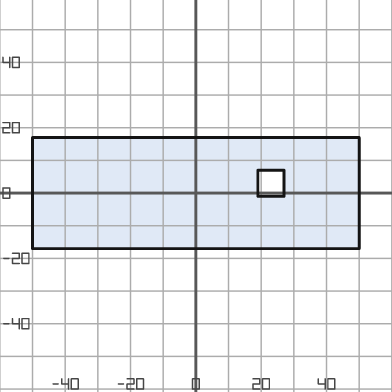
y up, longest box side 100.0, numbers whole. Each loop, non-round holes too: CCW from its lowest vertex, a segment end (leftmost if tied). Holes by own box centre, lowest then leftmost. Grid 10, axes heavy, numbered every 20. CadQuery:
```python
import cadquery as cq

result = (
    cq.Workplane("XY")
    .moveTo(-50.0, -17.0)
    .lineTo(50.0, -17.0)
    .lineTo(50.0, 17.0)
    .lineTo(-50.0, 17.0)
    .close()
    .moveTo(19.0, -1.0)
    .lineTo(27.0, -1.0)
    .lineTo(27.0, 7.0)
    .lineTo(19.0, 7.0)
    .close()
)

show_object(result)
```